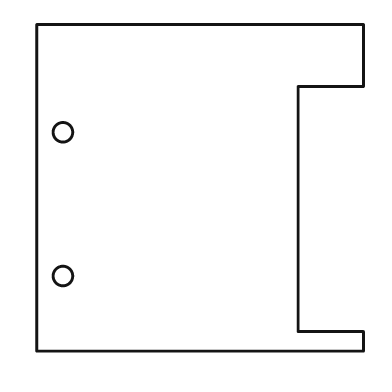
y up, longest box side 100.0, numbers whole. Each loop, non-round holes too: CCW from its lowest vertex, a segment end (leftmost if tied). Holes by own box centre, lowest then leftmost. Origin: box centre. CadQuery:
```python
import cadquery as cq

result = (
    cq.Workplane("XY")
    .moveTo(-50.0, -50.0)
    .lineTo(50.0, -50.0)
    .lineTo(50.0, -44.0)
    .lineTo(30.0, -44.0)
    .lineTo(30.0, 31.0)
    .lineTo(50.0, 31.0)
    .lineTo(50.0, 50.0)
    .lineTo(-50.0, 50.0)
    .close()
    .moveTo(-42.0, -27.0)
    .circle(3.0)
    .moveTo(-42.0, 17.0)
    .circle(3.0)
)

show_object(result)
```